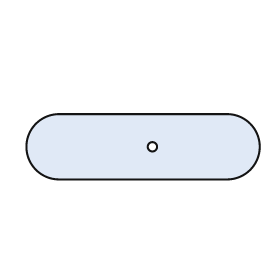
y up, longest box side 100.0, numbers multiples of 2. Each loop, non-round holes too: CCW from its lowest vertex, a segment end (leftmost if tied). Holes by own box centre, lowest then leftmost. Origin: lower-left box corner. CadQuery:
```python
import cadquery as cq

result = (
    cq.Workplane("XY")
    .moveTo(14.0, 0.0)
    .lineTo(86.0, 0.0)
    .threePointArc((100.0, 14.0), (86.0, 28.0))
    .lineTo(14.0, 28.0)
    .threePointArc((0.0, 14.0), (14.0, 0.0))
    .close()
    .moveTo(54.0, 14.0)
    .circle(2.0)
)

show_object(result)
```